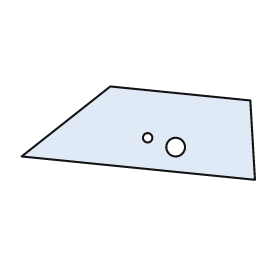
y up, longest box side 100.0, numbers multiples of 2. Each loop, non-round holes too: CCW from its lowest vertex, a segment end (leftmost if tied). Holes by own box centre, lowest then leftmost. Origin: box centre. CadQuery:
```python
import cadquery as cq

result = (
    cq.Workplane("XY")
    .moveTo(50.0, -20.0)
    .lineTo(48.0, 14.0)
    .lineTo(-12.0, 20.0)
    .lineTo(-50.0, -10.0)
    .close()
    .moveTo(16.0, -6.0)
    .circle(4.0)
    .moveTo(4.0, -2.0)
    .circle(2.0)
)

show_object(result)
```